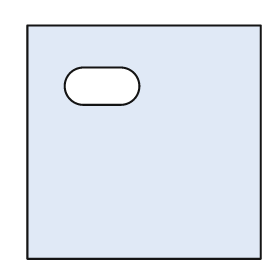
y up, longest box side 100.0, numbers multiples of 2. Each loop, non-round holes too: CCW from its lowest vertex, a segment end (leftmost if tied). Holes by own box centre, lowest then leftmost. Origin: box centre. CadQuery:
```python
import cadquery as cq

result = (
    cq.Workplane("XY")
    .moveTo(-50.0, -50.0)
    .lineTo(50.0, -50.0)
    .lineTo(50.0, 50.0)
    .lineTo(-50.0, 50.0)
    .close()
    .moveTo(-26.0, 16.0)
    .lineTo(-10.0, 16.0)
    .threePointArc((-2.0, 24.0), (-10.0, 32.0))
    .lineTo(-26.0, 32.0)
    .threePointArc((-34.0, 24.0), (-26.0, 16.0))
    .close()
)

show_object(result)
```